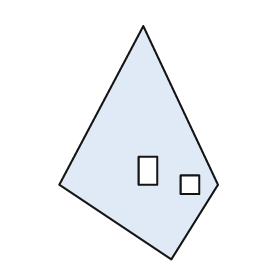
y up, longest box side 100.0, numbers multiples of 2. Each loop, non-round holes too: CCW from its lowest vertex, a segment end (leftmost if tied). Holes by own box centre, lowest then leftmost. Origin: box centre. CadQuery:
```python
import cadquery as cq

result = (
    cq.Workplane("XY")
    .moveTo(14.0, -50.0)
    .lineTo(34.0, -18.0)
    .lineTo(2.0, 50.0)
    .lineTo(-34.0, -18.0)
    .close()
    .moveTo(18.0, -22.0)
    .lineTo(26.0, -22.0)
    .lineTo(26.0, -14.0)
    .lineTo(18.0, -14.0)
    .close()
    .moveTo(0.0, -18.0)
    .lineTo(8.0, -18.0)
    .lineTo(8.0, -6.0)
    .lineTo(0.0, -6.0)
    .close()
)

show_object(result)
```